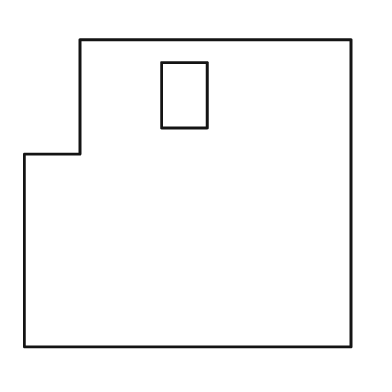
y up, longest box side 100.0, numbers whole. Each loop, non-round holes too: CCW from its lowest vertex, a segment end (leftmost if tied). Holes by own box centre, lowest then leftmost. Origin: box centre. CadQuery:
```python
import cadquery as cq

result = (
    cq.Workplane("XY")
    .moveTo(-50.0, -47.0)
    .lineTo(50.0, -47.0)
    .lineTo(50.0, 47.0)
    .lineTo(-33.0, 47.0)
    .lineTo(-33.0, 12.0)
    .lineTo(-50.0, 12.0)
    .close()
    .moveTo(-8.0, 20.0)
    .lineTo(6.0, 20.0)
    .lineTo(6.0, 40.0)
    .lineTo(-8.0, 40.0)
    .close()
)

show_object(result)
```